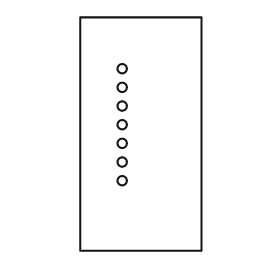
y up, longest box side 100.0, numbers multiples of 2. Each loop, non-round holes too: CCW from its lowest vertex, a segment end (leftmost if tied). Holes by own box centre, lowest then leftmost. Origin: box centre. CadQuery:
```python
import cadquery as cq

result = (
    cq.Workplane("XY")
    .moveTo(-26.0, -50.0)
    .lineTo(26.0, -50.0)
    .lineTo(26.0, 50.0)
    .lineTo(-26.0, 50.0)
    .close()
    .moveTo(-8.0, -20.0)
    .circle(2.0)
    .moveTo(-8.0, -12.0)
    .circle(2.0)
    .moveTo(-8.0, -4.0)
    .circle(2.0)
    .moveTo(-8.0, 4.0)
    .circle(2.0)
    .moveTo(-8.0, 12.0)
    .circle(2.0)
    .moveTo(-8.0, 20.0)
    .circle(2.0)
    .moveTo(-8.0, 28.0)
    .circle(2.0)
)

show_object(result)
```